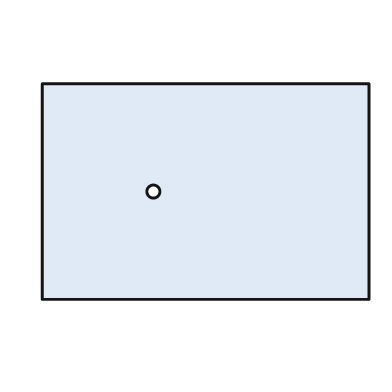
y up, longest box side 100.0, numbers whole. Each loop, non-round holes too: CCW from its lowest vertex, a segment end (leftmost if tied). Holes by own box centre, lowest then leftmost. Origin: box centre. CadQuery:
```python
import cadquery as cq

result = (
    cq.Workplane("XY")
    .moveTo(-50.0, -33.0)
    .lineTo(50.0, -33.0)
    .lineTo(50.0, 33.0)
    .lineTo(-50.0, 33.0)
    .close()
    .moveTo(-16.0, 0.0)
    .circle(2.0)
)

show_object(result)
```